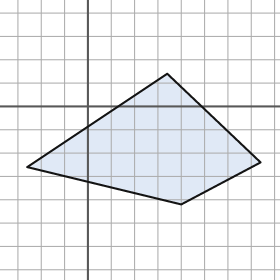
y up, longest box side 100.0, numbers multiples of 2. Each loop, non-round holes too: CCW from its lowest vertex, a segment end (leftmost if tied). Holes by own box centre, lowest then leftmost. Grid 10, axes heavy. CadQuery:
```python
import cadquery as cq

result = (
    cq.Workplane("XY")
    .moveTo(40.0, -42.0)
    .lineTo(74.0, -24.0)
    .lineTo(34.0, 14.0)
    .lineTo(-26.0, -26.0)
    .close()
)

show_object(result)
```